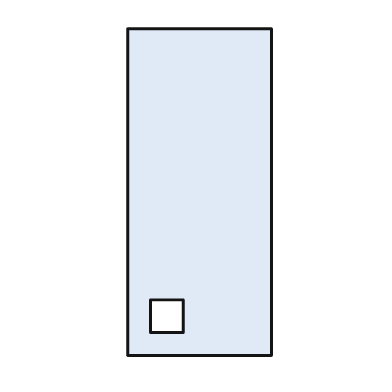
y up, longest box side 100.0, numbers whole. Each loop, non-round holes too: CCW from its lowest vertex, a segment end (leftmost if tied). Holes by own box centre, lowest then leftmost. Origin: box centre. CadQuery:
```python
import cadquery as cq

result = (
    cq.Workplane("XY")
    .moveTo(-22.0, -50.0)
    .lineTo(22.0, -50.0)
    .lineTo(22.0, 50.0)
    .lineTo(-22.0, 50.0)
    .close()
    .moveTo(-15.0, -43.0)
    .lineTo(-5.0, -43.0)
    .lineTo(-5.0, -33.0)
    .lineTo(-15.0, -33.0)
    .close()
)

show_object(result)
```